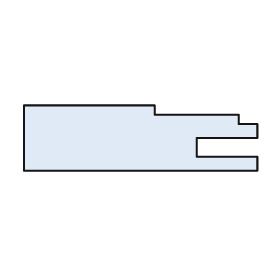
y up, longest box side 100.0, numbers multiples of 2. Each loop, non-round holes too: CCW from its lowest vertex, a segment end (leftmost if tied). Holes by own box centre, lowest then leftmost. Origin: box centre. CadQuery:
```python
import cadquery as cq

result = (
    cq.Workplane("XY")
    .moveTo(-50.0, -14.0)
    .lineTo(50.0, -14.0)
    .lineTo(50.0, -8.0)
    .lineTo(24.0, -8.0)
    .lineTo(24.0, 0.0)
    .lineTo(50.0, 0.0)
    .lineTo(50.0, 6.0)
    .lineTo(42.0, 6.0)
    .lineTo(42.0, 10.0)
    .lineTo(6.0, 10.0)
    .lineTo(6.0, 14.0)
    .lineTo(-50.0, 14.0)
    .close()
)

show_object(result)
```